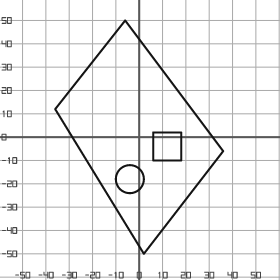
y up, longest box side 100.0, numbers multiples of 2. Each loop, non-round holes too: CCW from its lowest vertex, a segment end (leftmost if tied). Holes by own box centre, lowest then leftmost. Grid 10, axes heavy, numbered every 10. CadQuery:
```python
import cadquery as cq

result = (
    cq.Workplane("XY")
    .moveTo(2.0, -50.0)
    .lineTo(36.0, -6.0)
    .lineTo(-6.0, 50.0)
    .lineTo(-36.0, 12.0)
    .close()
    .moveTo(-4.0, -18.0)
    .circle(6.0)
    .moveTo(6.0, -10.0)
    .lineTo(18.0, -10.0)
    .lineTo(18.0, 2.0)
    .lineTo(6.0, 2.0)
    .close()
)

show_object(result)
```